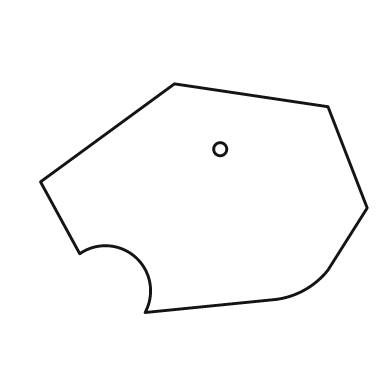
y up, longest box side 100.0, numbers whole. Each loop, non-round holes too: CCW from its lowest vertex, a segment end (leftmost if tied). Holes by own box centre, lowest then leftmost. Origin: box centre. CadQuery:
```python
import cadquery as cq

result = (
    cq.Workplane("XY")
    .moveTo(-18.0, -35.0)
    .lineTo(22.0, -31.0)
    .threePointArc((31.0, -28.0), (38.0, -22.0))
    .lineTo(50.0, -3.0)
    .lineTo(38.0, 28.0)
    .lineTo(-9.0, 35.0)
    .lineTo(-50.0, 5.0)
    .lineTo(-38.0, -17.0)
    .threePointArc((-21.0, -18.0), (-18.0, -35.0))
    .close()
    .moveTo(5.0, 15.0)
    .circle(2.0)
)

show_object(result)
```